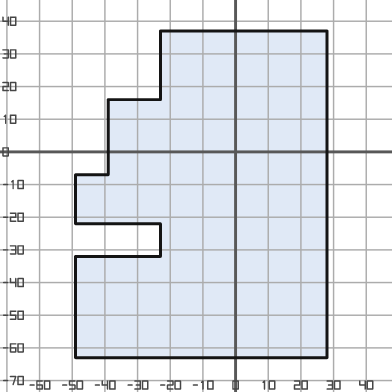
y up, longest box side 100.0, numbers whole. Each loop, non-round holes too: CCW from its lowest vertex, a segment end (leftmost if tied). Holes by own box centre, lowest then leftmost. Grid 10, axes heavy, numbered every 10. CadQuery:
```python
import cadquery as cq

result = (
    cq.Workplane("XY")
    .moveTo(-49.0, -63.0)
    .lineTo(28.0, -63.0)
    .lineTo(28.0, 37.0)
    .lineTo(-23.0, 37.0)
    .lineTo(-23.0, 16.0)
    .lineTo(-39.0, 16.0)
    .lineTo(-39.0, -7.0)
    .lineTo(-49.0, -7.0)
    .lineTo(-49.0, -22.0)
    .lineTo(-23.0, -22.0)
    .lineTo(-23.0, -32.0)
    .lineTo(-49.0, -32.0)
    .close()
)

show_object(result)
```